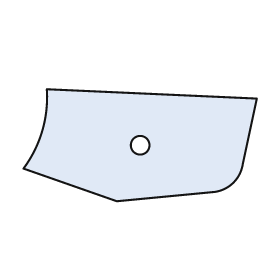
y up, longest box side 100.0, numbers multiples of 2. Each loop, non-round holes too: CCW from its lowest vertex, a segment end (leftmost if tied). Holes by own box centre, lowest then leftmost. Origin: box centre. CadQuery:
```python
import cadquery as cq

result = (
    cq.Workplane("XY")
    .moveTo(-10.0, -24.0)
    .lineTo(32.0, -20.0)
    .threePointArc((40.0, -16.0), (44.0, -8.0))
    .lineTo(50.0, 20.0)
    .lineTo(-40.0, 24.0)
    .threePointArc((-42.0, 6.0), (-50.0, -10.0))
    .close()
    .moveTo(0.0, 0.0)
    .circle(4.0)
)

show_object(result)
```